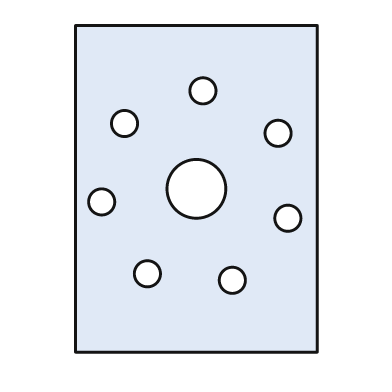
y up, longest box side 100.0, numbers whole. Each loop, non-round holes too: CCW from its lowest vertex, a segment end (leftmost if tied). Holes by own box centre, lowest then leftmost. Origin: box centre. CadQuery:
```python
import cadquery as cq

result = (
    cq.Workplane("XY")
    .moveTo(-37.0, -50.0)
    .lineTo(37.0, -50.0)
    .lineTo(37.0, 50.0)
    .lineTo(-37.0, 50.0)
    .close()
    .moveTo(11.0, -28.0)
    .circle(4.0)
    .moveTo(-15.0, -26.0)
    .circle(4.0)
    .moveTo(28.0, -9.0)
    .circle(4.0)
    .moveTo(-29.0, -4.0)
    .circle(4.0)
    .moveTo(0.0, 0.0)
    .circle(9.0)
    .moveTo(25.0, 17.0)
    .circle(4.0)
    .moveTo(-22.0, 20.0)
    .circle(4.0)
    .moveTo(2.0, 30.0)
    .circle(4.0)
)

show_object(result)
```